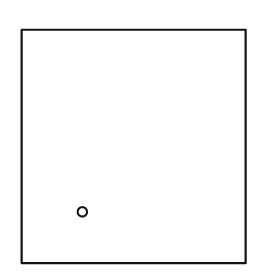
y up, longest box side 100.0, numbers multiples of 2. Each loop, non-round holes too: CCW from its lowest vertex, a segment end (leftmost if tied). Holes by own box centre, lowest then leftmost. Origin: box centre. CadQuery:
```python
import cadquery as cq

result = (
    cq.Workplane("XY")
    .moveTo(-48.0, -50.0)
    .lineTo(48.0, -50.0)
    .lineTo(48.0, 50.0)
    .lineTo(-48.0, 50.0)
    .close()
    .moveTo(-22.0, -28.0)
    .circle(2.0)
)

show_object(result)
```